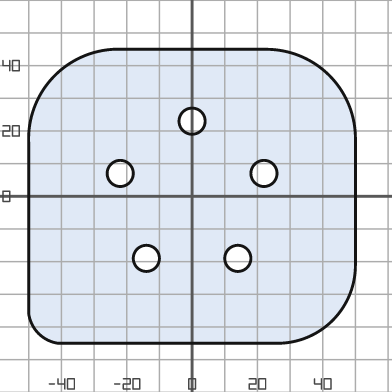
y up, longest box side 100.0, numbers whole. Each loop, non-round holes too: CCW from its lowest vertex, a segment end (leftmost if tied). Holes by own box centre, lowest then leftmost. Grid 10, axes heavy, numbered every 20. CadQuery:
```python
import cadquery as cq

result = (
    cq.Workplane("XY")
    .moveTo(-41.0, -45.0)
    .lineTo(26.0, -45.0)
    .threePointArc((43.0, -38.0), (50.0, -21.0))
    .lineTo(50.0, 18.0)
    .threePointArc((42.0, 37.0), (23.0, 45.0))
    .lineTo(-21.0, 45.0)
    .threePointArc((-42.0, 37.0), (-50.0, 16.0))
    .lineTo(-50.0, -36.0)
    .threePointArc((-47.0, -42.0), (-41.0, -45.0))
    .close()
    .moveTo(-14.0, -19.0)
    .circle(4.0)
    .moveTo(14.0, -19.0)
    .circle(4.0)
    .moveTo(-22.0, 7.0)
    .circle(4.0)
    .moveTo(22.0, 7.0)
    .circle(4.0)
    .moveTo(0.0, 23.0)
    .circle(4.0)
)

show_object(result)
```